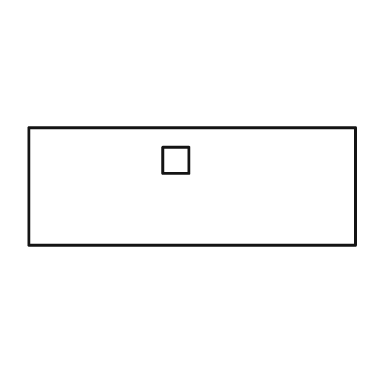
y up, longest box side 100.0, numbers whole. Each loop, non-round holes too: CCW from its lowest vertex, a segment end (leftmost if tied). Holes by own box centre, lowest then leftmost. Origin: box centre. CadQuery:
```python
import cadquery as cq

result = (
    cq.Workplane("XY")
    .moveTo(-50.0, -18.0)
    .lineTo(50.0, -18.0)
    .lineTo(50.0, 18.0)
    .lineTo(-50.0, 18.0)
    .close()
    .moveTo(-9.0, 4.0)
    .lineTo(-1.0, 4.0)
    .lineTo(-1.0, 12.0)
    .lineTo(-9.0, 12.0)
    .close()
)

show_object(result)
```